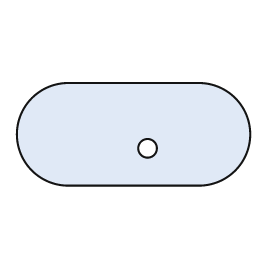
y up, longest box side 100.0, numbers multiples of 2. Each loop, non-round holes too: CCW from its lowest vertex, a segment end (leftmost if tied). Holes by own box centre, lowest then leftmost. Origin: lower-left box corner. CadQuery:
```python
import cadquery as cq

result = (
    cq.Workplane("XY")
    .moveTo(22.0, 0.0)
    .lineTo(78.0, 0.0)
    .threePointArc((100.0, 22.0), (78.0, 44.0))
    .lineTo(22.0, 44.0)
    .threePointArc((0.0, 22.0), (22.0, 0.0))
    .close()
    .moveTo(56.0, 16.0)
    .circle(4.0)
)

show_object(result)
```